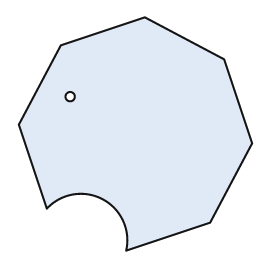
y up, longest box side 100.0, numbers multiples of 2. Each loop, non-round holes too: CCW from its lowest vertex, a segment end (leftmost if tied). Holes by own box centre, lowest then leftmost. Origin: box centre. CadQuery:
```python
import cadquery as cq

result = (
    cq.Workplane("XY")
    .moveTo(-4.0, -50.0)
    .lineTo(32.0, -38.0)
    .lineTo(50.0, -4.0)
    .lineTo(38.0, 32.0)
    .lineTo(4.0, 50.0)
    .lineTo(-32.0, 38.0)
    .lineTo(-50.0, 4.0)
    .lineTo(-38.0, -32.0)
    .threePointArc((-14.0, -28.0), (-4.0, -50.0))
    .close()
    .moveTo(-28.0, 16.0)
    .circle(2.0)
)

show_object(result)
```